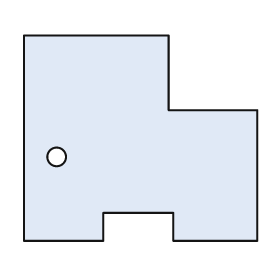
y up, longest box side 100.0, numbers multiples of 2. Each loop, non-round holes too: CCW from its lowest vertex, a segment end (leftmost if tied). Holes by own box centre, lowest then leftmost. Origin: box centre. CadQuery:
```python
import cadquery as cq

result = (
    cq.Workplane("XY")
    .moveTo(-50.0, -44.0)
    .lineTo(-16.0, -44.0)
    .lineTo(-16.0, -32.0)
    .lineTo(14.0, -32.0)
    .lineTo(14.0, -44.0)
    .lineTo(50.0, -44.0)
    .lineTo(50.0, 12.0)
    .lineTo(12.0, 12.0)
    .lineTo(12.0, 44.0)
    .lineTo(-50.0, 44.0)
    .close()
    .moveTo(-36.0, -8.0)
    .circle(4.0)
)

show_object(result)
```